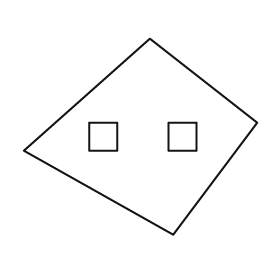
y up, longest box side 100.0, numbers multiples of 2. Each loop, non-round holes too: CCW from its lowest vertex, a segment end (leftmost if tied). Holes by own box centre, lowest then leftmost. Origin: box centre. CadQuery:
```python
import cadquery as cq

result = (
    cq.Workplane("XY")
    .moveTo(14.0, -42.0)
    .lineTo(50.0, 6.0)
    .lineTo(4.0, 42.0)
    .lineTo(-50.0, -6.0)
    .close()
    .moveTo(-22.0, -6.0)
    .lineTo(-10.0, -6.0)
    .lineTo(-10.0, 6.0)
    .lineTo(-22.0, 6.0)
    .close()
    .moveTo(12.0, -6.0)
    .lineTo(24.0, -6.0)
    .lineTo(24.0, 6.0)
    .lineTo(12.0, 6.0)
    .close()
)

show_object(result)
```